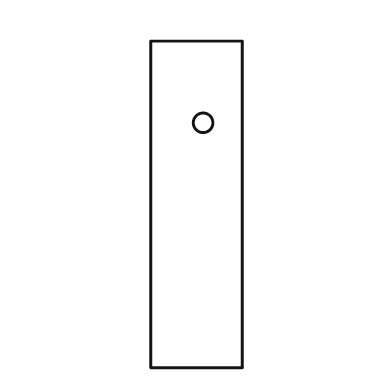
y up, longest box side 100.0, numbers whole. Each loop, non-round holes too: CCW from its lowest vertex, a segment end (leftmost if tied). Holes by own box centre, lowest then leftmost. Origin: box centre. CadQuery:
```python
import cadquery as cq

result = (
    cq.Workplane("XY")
    .moveTo(-14.0, -50.0)
    .lineTo(14.0, -50.0)
    .lineTo(14.0, 50.0)
    .lineTo(-14.0, 50.0)
    .close()
    .moveTo(2.0, 25.0)
    .circle(3.0)
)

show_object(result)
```